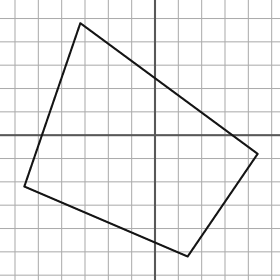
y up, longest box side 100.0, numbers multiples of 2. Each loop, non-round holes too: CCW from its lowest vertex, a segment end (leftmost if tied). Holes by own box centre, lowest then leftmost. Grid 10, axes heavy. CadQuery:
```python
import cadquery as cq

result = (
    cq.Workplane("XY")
    .moveTo(14.0, -52.0)
    .lineTo(44.0, -8.0)
    .lineTo(-32.0, 48.0)
    .lineTo(-56.0, -22.0)
    .close()
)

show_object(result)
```